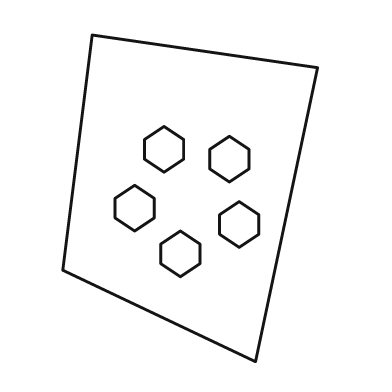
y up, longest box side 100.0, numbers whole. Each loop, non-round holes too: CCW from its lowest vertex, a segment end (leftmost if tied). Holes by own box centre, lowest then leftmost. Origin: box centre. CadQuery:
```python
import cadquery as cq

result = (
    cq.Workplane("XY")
    .moveTo(20.0, -50.0)
    .lineTo(39.0, 40.0)
    .lineTo(-30.0, 50.0)
    .lineTo(-39.0, -22.0)
    .close()
    .moveTo(-3.0, -24.0)
    .lineTo(3.0, -20.0)
    .lineTo(3.0, -14.0)
    .lineTo(-3.0, -10.0)
    .lineTo(-9.0, -14.0)
    .lineTo(-9.0, -20.0)
    .close()
    .moveTo(15.0, -15.0)
    .lineTo(21.0, -11.0)
    .lineTo(21.0, -5.0)
    .lineTo(15.0, -1.0)
    .lineTo(9.0, -5.0)
    .lineTo(9.0, -11.0)
    .close()
    .moveTo(-17.0, -10.0)
    .lineTo(-11.0, -6.0)
    .lineTo(-11.0, 0.0)
    .lineTo(-17.0, 4.0)
    .lineTo(-23.0, 0.0)
    .lineTo(-23.0, -6.0)
    .close()
    .moveTo(12.0, 5.0)
    .lineTo(18.0, 9.0)
    .lineTo(18.0, 15.0)
    .lineTo(12.0, 19.0)
    .lineTo(6.0, 15.0)
    .lineTo(6.0, 9.0)
    .close()
    .moveTo(-8.0, 8.0)
    .lineTo(-2.0, 12.0)
    .lineTo(-2.0, 18.0)
    .lineTo(-8.0, 22.0)
    .lineTo(-14.0, 18.0)
    .lineTo(-14.0, 12.0)
    .close()
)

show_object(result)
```